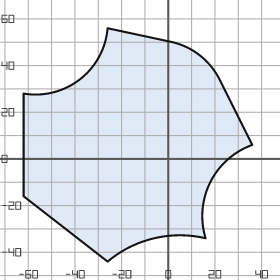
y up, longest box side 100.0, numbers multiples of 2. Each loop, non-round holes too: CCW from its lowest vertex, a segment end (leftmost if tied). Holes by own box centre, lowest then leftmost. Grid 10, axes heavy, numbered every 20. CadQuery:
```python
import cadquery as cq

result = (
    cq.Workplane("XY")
    .moveTo(-26.0, -44.0)
    .threePointArc((-6.0, -34.0), (16.0, -34.0))
    .threePointArc((18.0, -10.0), (36.0, 6.0))
    .lineTo(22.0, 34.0)
    .threePointArc((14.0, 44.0), (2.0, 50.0))
    .lineTo(-26.0, 56.0)
    .threePointArc((-38.0, 34.0), (-62.0, 28.0))
    .lineTo(-62.0, -16.0)
    .close()
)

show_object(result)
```